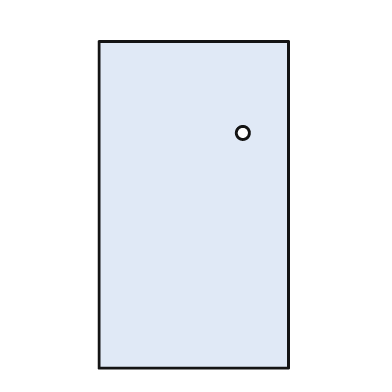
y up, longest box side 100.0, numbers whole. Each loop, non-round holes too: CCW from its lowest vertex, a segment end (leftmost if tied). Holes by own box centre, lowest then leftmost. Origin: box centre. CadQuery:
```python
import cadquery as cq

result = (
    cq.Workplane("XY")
    .moveTo(-29.0, -50.0)
    .lineTo(29.0, -50.0)
    .lineTo(29.0, 50.0)
    .lineTo(-29.0, 50.0)
    .close()
    .moveTo(15.0, 22.0)
    .circle(2.0)
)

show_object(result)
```